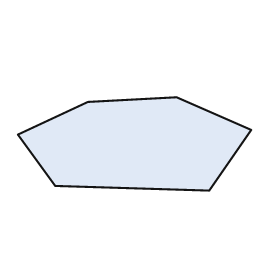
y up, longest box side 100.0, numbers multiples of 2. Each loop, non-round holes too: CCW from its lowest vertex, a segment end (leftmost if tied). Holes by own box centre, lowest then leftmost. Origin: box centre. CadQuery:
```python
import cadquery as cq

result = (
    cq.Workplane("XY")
    .moveTo(32.0, -20.0)
    .lineTo(50.0, 6.0)
    .lineTo(18.0, 20.0)
    .lineTo(-20.0, 18.0)
    .lineTo(-50.0, 4.0)
    .lineTo(-34.0, -18.0)
    .close()
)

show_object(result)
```